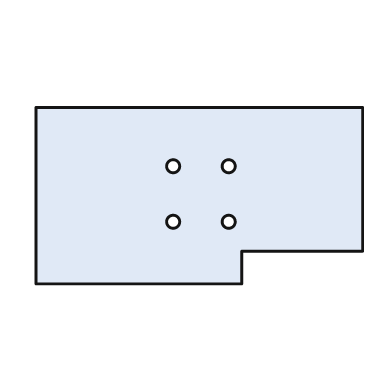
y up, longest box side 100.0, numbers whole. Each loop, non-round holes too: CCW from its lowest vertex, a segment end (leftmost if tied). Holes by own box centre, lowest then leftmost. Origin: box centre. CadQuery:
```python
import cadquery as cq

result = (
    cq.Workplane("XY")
    .moveTo(-50.0, -27.0)
    .lineTo(13.0, -27.0)
    .lineTo(13.0, -17.0)
    .lineTo(50.0, -17.0)
    .lineTo(50.0, 27.0)
    .lineTo(-50.0, 27.0)
    .close()
    .moveTo(-8.0, -8.0)
    .circle(2.0)
    .moveTo(9.0, -8.0)
    .circle(2.0)
    .moveTo(-8.0, 9.0)
    .circle(2.0)
    .moveTo(9.0, 9.0)
    .circle(2.0)
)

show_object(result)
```